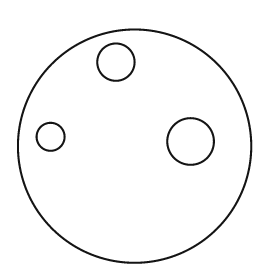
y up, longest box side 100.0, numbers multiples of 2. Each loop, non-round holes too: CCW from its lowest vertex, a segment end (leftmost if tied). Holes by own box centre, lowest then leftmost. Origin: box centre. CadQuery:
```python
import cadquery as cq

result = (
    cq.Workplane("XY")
    .moveTo(0.0, 0.0)
    .circle(50.0)
    .moveTo(24.0, 2.0)
    .circle(10.0)
    .moveTo(-36.0, 4.0)
    .circle(6.0)
    .moveTo(-8.0, 36.0)
    .circle(8.0)
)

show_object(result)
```